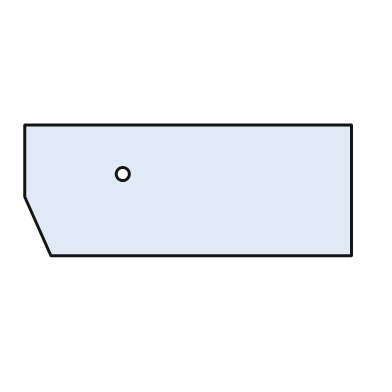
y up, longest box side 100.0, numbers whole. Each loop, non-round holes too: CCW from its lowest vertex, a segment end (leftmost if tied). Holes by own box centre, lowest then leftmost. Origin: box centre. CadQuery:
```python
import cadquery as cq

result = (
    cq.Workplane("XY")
    .moveTo(-42.0, -20.0)
    .lineTo(50.0, -20.0)
    .lineTo(50.0, 20.0)
    .lineTo(-50.0, 20.0)
    .lineTo(-50.0, -2.0)
    .close()
    .moveTo(-20.0, 5.0)
    .circle(2.0)
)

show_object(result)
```